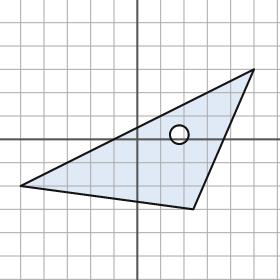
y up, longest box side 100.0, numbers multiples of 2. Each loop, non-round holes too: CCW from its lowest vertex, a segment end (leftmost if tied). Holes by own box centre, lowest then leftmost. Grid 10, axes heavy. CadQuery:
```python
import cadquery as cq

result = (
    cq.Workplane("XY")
    .moveTo(24.0, -30.0)
    .lineTo(50.0, 30.0)
    .lineTo(-50.0, -20.0)
    .close()
    .moveTo(18.0, 2.0)
    .circle(4.0)
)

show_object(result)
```